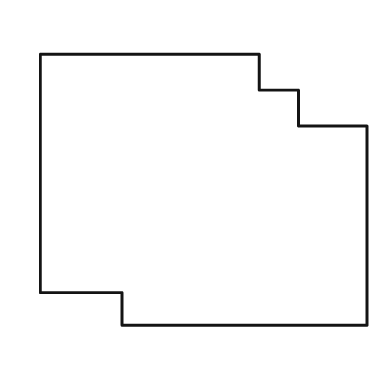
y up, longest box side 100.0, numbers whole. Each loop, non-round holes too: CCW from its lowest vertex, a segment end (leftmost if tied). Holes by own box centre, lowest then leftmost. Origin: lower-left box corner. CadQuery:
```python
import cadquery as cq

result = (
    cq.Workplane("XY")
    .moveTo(25.0, 0.0)
    .lineTo(100.0, 0.0)
    .lineTo(100.0, 61.0)
    .lineTo(79.0, 61.0)
    .lineTo(79.0, 72.0)
    .lineTo(67.0, 72.0)
    .lineTo(67.0, 83.0)
    .lineTo(0.0, 83.0)
    .lineTo(0.0, 10.0)
    .lineTo(25.0, 10.0)
    .close()
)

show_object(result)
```